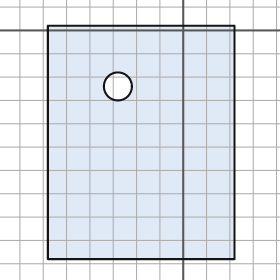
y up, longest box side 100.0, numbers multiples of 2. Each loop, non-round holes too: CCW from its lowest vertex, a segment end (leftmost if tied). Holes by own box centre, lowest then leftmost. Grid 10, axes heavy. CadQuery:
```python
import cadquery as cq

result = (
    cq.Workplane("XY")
    .moveTo(-58.0, -98.0)
    .lineTo(22.0, -98.0)
    .lineTo(22.0, 2.0)
    .lineTo(-58.0, 2.0)
    .close()
    .moveTo(-28.0, -24.0)
    .circle(6.0)
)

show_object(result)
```